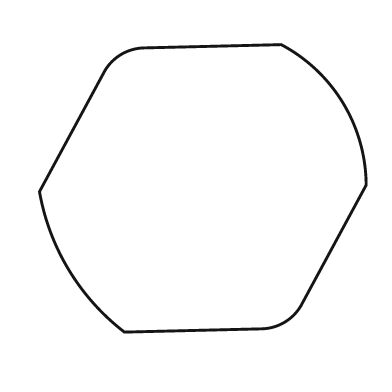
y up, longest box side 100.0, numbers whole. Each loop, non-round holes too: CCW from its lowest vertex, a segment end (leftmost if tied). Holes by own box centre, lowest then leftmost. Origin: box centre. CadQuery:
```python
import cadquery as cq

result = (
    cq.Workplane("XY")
    .moveTo(-24.0, -44.0)
    .lineTo(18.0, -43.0)
    .threePointArc((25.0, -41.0), (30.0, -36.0))
    .lineTo(50.0, 1.0)
    .threePointArc((43.0, 26.0), (24.0, 44.0))
    .lineTo(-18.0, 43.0)
    .threePointArc((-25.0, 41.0), (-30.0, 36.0))
    .lineTo(-50.0, -1.0)
    .threePointArc((-41.0, -25.0), (-24.0, -44.0))
    .close()
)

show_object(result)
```